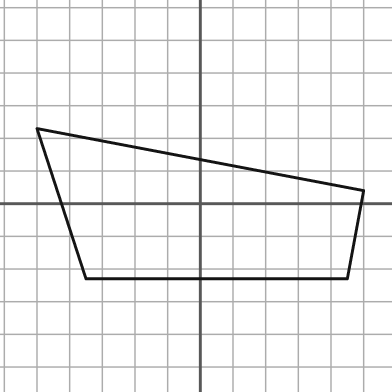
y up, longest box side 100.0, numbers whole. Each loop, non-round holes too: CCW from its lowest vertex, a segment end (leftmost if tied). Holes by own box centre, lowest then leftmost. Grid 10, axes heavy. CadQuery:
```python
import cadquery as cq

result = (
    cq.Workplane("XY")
    .moveTo(-35.0, -23.0)
    .lineTo(45.0, -23.0)
    .lineTo(50.0, 4.0)
    .lineTo(-50.0, 23.0)
    .close()
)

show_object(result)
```